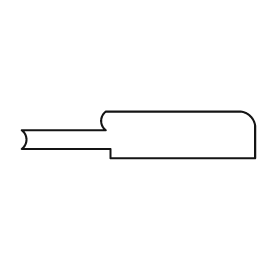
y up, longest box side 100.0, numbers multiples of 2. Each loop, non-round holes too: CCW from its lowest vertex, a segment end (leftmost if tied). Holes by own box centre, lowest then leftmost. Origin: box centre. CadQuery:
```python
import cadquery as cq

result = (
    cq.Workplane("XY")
    .moveTo(-12.0, -10.0)
    .lineTo(50.0, -10.0)
    .lineTo(50.0, 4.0)
    .threePointArc((48.0, 8.0), (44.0, 10.0))
    .lineTo(-14.0, 10.0)
    .threePointArc((-16.0, 6.0), (-14.0, 2.0))
    .lineTo(-50.0, 2.0)
    .threePointArc((-48.0, -2.0), (-50.0, -6.0))
    .lineTo(-12.0, -6.0)
    .close()
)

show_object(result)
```